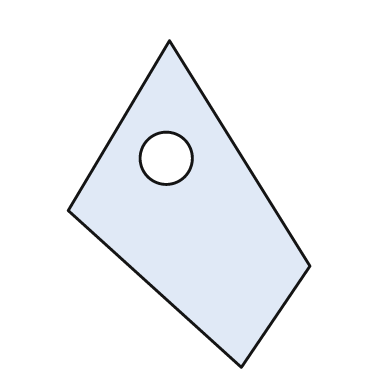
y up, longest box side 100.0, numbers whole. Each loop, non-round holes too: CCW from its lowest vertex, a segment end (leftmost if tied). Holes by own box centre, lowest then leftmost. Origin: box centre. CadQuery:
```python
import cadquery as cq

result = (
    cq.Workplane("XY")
    .moveTo(16.0, -50.0)
    .lineTo(37.0, -19.0)
    .lineTo(-6.0, 50.0)
    .lineTo(-37.0, -2.0)
    .close()
    .moveTo(-7.0, 14.0)
    .circle(8.0)
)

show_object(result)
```